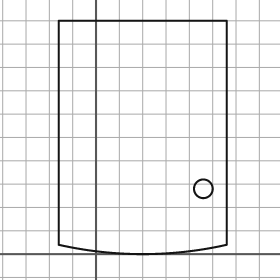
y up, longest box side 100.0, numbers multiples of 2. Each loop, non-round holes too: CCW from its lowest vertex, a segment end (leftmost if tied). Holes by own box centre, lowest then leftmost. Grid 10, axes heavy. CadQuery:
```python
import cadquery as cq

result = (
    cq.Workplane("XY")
    .moveTo(-16.0, 4.0)
    .threePointArc((20.0, 0.0), (56.0, 4.0))
    .lineTo(56.0, 100.0)
    .lineTo(-16.0, 100.0)
    .close()
    .moveTo(46.0, 28.0)
    .circle(4.0)
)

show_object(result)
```